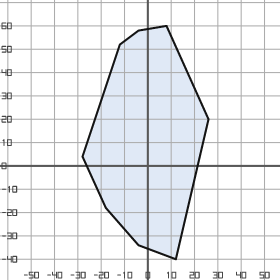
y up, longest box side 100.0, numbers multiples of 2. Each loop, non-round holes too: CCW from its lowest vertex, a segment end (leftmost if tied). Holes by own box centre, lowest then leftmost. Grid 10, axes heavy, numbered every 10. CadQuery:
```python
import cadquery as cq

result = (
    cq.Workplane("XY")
    .moveTo(12.0, -40.0)
    .lineTo(26.0, 20.0)
    .lineTo(8.0, 60.0)
    .lineTo(-4.0, 58.0)
    .lineTo(-12.0, 52.0)
    .lineTo(-28.0, 4.0)
    .lineTo(-18.0, -18.0)
    .lineTo(-4.0, -34.0)
    .close()
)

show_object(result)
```